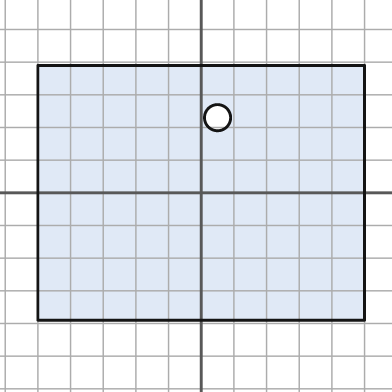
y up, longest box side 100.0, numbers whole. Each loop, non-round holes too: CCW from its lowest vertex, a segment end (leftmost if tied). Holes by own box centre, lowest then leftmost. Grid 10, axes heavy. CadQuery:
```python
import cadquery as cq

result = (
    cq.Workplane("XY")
    .moveTo(-50.0, -39.0)
    .lineTo(50.0, -39.0)
    .lineTo(50.0, 39.0)
    .lineTo(-50.0, 39.0)
    .close()
    .moveTo(5.0, 23.0)
    .circle(4.0)
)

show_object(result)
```